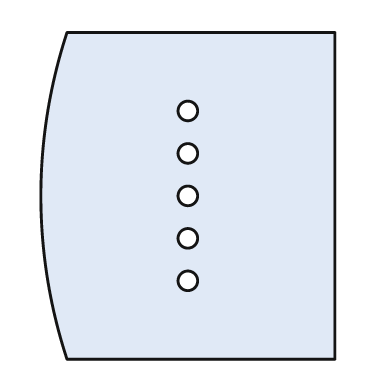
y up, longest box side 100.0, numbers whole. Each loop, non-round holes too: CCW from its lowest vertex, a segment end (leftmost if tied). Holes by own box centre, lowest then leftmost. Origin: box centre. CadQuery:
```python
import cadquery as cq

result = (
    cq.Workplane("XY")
    .moveTo(-37.0, -50.0)
    .lineTo(45.0, -50.0)
    .lineTo(45.0, 50.0)
    .lineTo(-37.0, 50.0)
    .threePointArc((-45.0, 0.0), (-37.0, -50.0))
    .close()
    .moveTo(0.0, -26.0)
    .circle(3.0)
    .moveTo(0.0, -13.0)
    .circle(3.0)
    .moveTo(0.0, 0.0)
    .circle(3.0)
    .moveTo(0.0, 13.0)
    .circle(3.0)
    .moveTo(0.0, 26.0)
    .circle(3.0)
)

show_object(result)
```